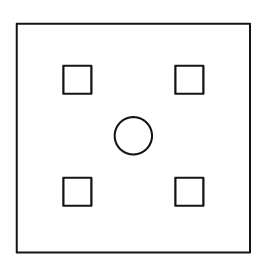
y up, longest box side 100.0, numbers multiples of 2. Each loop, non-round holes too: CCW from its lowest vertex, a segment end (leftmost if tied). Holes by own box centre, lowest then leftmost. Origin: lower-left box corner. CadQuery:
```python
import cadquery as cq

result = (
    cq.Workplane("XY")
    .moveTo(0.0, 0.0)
    .lineTo(100.0, 0.0)
    .lineTo(100.0, 98.0)
    .lineTo(0.0, 98.0)
    .close()
    .moveTo(20.0, 20.0)
    .lineTo(32.0, 20.0)
    .lineTo(32.0, 32.0)
    .lineTo(20.0, 32.0)
    .close()
    .moveTo(68.0, 20.0)
    .lineTo(80.0, 20.0)
    .lineTo(80.0, 32.0)
    .lineTo(68.0, 32.0)
    .close()
    .moveTo(50.0, 50.0)
    .circle(8.0)
    .moveTo(20.0, 68.0)
    .lineTo(32.0, 68.0)
    .lineTo(32.0, 80.0)
    .lineTo(20.0, 80.0)
    .close()
    .moveTo(68.0, 68.0)
    .lineTo(80.0, 68.0)
    .lineTo(80.0, 80.0)
    .lineTo(68.0, 80.0)
    .close()
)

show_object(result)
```